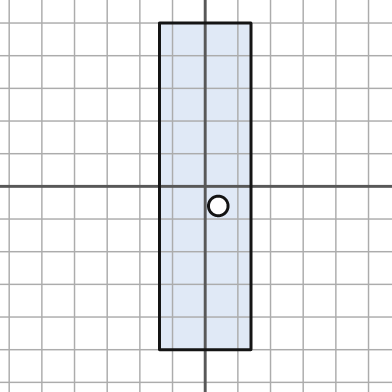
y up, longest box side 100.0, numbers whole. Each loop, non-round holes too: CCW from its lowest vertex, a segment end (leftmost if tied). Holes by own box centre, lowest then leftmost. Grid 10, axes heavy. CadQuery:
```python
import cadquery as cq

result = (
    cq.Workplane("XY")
    .moveTo(-14.0, -50.0)
    .lineTo(14.0, -50.0)
    .lineTo(14.0, 50.0)
    .lineTo(-14.0, 50.0)
    .close()
    .moveTo(4.0, -6.0)
    .circle(3.0)
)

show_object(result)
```